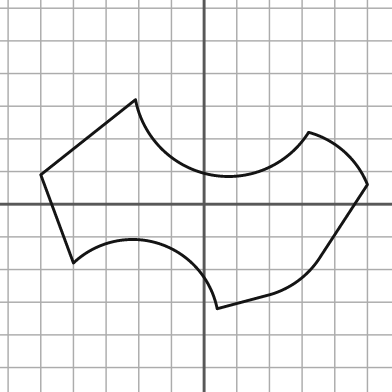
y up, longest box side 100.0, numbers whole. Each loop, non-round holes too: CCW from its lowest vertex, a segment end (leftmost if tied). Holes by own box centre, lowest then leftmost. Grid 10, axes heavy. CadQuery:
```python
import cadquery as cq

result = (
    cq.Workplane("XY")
    .moveTo(4.0, -32.0)
    .lineTo(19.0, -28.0)
    .threePointArc((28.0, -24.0), (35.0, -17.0))
    .lineTo(50.0, 6.0)
    .threePointArc((43.0, 16.0), (32.0, 22.0))
    .threePointArc((2.0, 9.0), (-21.0, 32.0))
    .lineTo(-50.0, 9.0)
    .lineTo(-40.0, -18.0)
    .threePointArc((-14.0, -12.0), (4.0, -32.0))
    .close()
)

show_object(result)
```